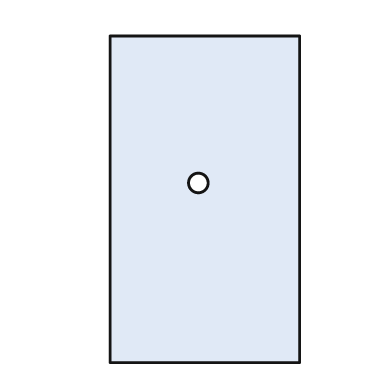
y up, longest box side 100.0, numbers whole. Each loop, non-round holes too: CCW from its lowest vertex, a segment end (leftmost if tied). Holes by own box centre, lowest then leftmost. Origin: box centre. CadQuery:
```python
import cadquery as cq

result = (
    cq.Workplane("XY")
    .moveTo(-29.0, -50.0)
    .lineTo(29.0, -50.0)
    .lineTo(29.0, 50.0)
    .lineTo(-29.0, 50.0)
    .close()
    .moveTo(-2.0, 5.0)
    .circle(3.0)
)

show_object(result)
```